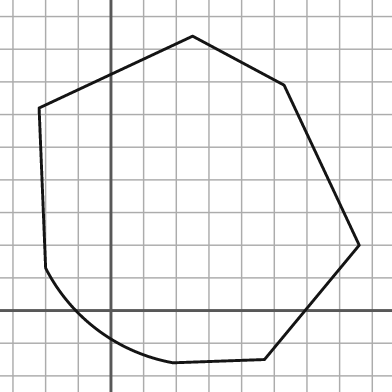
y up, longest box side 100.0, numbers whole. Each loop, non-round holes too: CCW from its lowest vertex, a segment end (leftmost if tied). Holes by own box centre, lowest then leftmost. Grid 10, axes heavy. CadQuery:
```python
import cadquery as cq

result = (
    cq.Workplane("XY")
    .moveTo(19.0, -16.0)
    .lineTo(47.0, -15.0)
    .lineTo(76.0, 20.0)
    .lineTo(53.0, 69.0)
    .lineTo(25.0, 84.0)
    .lineTo(-22.0, 62.0)
    .lineTo(-20.0, 13.0)
    .threePointArc((-4.0, -6.0), (19.0, -16.0))
    .close()
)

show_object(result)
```